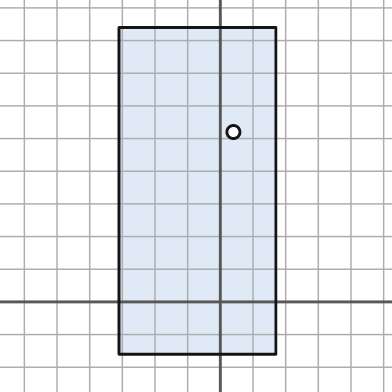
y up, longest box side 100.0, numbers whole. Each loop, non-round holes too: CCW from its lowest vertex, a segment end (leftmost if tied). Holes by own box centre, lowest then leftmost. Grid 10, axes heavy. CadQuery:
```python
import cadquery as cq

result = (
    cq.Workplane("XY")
    .moveTo(-31.0, -16.0)
    .lineTo(17.0, -16.0)
    .lineTo(17.0, 84.0)
    .lineTo(-31.0, 84.0)
    .close()
    .moveTo(4.0, 52.0)
    .circle(2.0)
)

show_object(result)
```